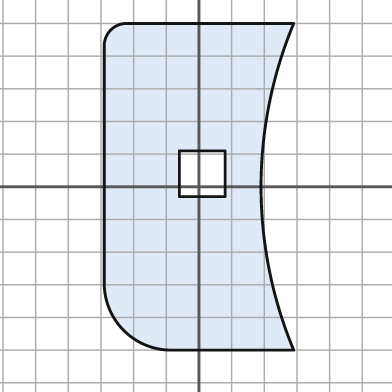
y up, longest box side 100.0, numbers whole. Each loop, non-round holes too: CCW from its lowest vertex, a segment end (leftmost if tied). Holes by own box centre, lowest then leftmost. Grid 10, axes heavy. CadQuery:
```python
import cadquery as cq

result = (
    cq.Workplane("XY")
    .moveTo(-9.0, -50.0)
    .lineTo(29.0, -50.0)
    .threePointArc((19.0, 0.0), (29.0, 50.0))
    .lineTo(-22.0, 50.0)
    .threePointArc((-27.0, 48.0), (-29.0, 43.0))
    .lineTo(-29.0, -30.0)
    .threePointArc((-23.0, -44.0), (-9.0, -50.0))
    .close()
    .moveTo(-6.0, -3.0)
    .lineTo(8.0, -3.0)
    .lineTo(8.0, 11.0)
    .lineTo(-6.0, 11.0)
    .close()
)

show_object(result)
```